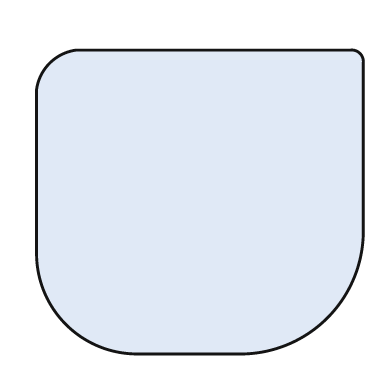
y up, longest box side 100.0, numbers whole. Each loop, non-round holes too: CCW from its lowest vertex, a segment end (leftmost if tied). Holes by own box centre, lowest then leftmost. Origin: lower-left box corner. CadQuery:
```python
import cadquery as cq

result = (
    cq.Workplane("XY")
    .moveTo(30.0, 0.0)
    .lineTo(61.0, 0.0)
    .threePointArc((89.0, 11.0), (100.0, 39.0))
    .lineTo(100.0, 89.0)
    .threePointArc((99.0, 92.0), (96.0, 93.0))
    .lineTo(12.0, 93.0)
    .threePointArc((4.0, 89.0), (0.0, 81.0))
    .lineTo(0.0, 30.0)
    .threePointArc((9.0, 9.0), (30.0, 0.0))
    .close()
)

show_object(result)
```